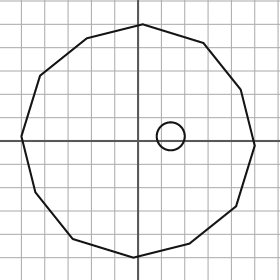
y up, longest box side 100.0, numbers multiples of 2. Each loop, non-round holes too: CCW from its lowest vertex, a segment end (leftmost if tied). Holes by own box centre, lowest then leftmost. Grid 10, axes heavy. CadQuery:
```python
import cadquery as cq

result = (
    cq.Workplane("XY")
    .moveTo(-2.0, -50.0)
    .lineTo(22.0, -44.0)
    .lineTo(42.0, -28.0)
    .lineTo(50.0, -2.0)
    .lineTo(44.0, 22.0)
    .lineTo(28.0, 42.0)
    .lineTo(2.0, 50.0)
    .lineTo(-22.0, 44.0)
    .lineTo(-42.0, 28.0)
    .lineTo(-50.0, 2.0)
    .lineTo(-44.0, -22.0)
    .lineTo(-28.0, -42.0)
    .close()
    .moveTo(14.0, 2.0)
    .circle(6.0)
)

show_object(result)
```